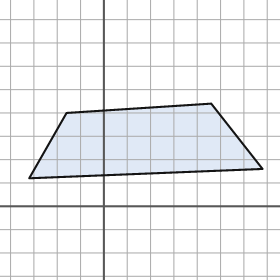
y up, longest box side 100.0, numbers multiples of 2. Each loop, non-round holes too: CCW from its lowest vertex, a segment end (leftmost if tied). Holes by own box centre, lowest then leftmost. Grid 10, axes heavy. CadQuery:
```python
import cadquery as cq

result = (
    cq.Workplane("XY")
    .moveTo(-32.0, 12.0)
    .lineTo(68.0, 16.0)
    .lineTo(46.0, 44.0)
    .lineTo(-16.0, 40.0)
    .close()
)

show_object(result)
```